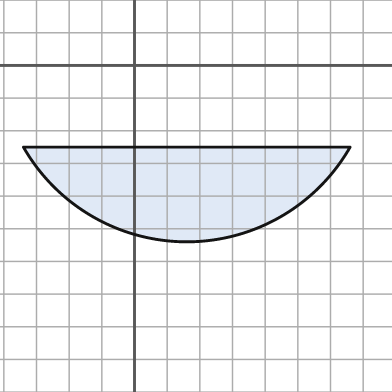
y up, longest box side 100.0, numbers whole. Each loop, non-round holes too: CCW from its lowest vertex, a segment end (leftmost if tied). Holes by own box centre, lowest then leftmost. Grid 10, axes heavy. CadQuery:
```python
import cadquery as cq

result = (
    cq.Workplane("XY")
    .moveTo(-34.0, -25.0)
    .threePointArc((16.0, -54.0), (66.0, -25.0))
    .close()
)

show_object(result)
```